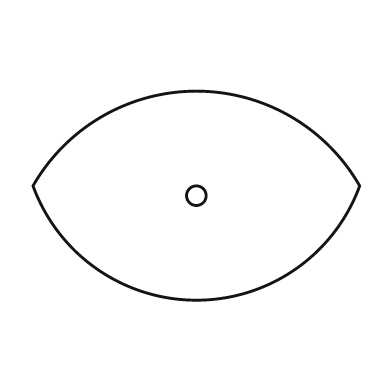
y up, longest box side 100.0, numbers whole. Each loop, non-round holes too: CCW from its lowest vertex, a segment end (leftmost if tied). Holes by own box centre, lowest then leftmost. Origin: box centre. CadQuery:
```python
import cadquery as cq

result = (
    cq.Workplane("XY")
    .moveTo(-50.0, 3.0)
    .threePointArc((0.0, -32.0), (50.0, 3.0))
    .threePointArc((0.0, 32.0), (-50.0, 3.0))
    .close()
    .moveTo(0.0, 0.0)
    .circle(3.0)
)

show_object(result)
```